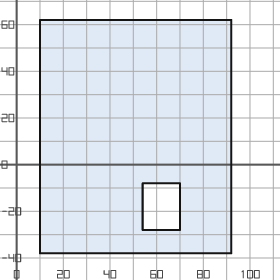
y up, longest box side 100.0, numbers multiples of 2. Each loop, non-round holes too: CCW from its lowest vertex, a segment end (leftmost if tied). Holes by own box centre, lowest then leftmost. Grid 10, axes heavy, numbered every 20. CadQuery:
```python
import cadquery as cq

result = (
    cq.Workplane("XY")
    .moveTo(10.0, -38.0)
    .lineTo(92.0, -38.0)
    .lineTo(92.0, 62.0)
    .lineTo(10.0, 62.0)
    .close()
    .moveTo(54.0, -28.0)
    .lineTo(70.0, -28.0)
    .lineTo(70.0, -8.0)
    .lineTo(54.0, -8.0)
    .close()
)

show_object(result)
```